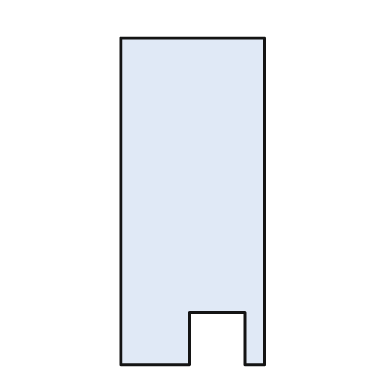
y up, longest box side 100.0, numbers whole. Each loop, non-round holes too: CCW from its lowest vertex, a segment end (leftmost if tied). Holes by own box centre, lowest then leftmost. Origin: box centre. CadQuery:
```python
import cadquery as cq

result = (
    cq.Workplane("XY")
    .moveTo(-22.0, -50.0)
    .lineTo(-1.0, -50.0)
    .lineTo(-1.0, -34.0)
    .lineTo(16.0, -34.0)
    .lineTo(16.0, -50.0)
    .lineTo(22.0, -50.0)
    .lineTo(22.0, 50.0)
    .lineTo(-22.0, 50.0)
    .close()
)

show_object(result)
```